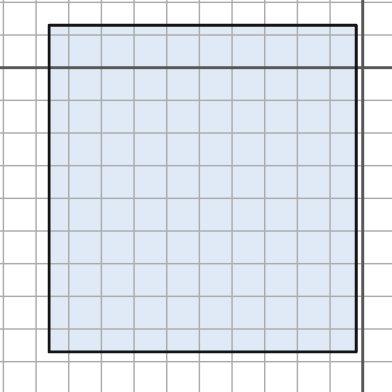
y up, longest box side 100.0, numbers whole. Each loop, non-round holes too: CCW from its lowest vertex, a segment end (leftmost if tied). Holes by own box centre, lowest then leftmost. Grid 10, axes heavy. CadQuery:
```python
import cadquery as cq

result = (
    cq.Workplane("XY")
    .moveTo(-96.0, -87.0)
    .lineTo(-2.0, -87.0)
    .lineTo(-2.0, 13.0)
    .lineTo(-96.0, 13.0)
    .close()
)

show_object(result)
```